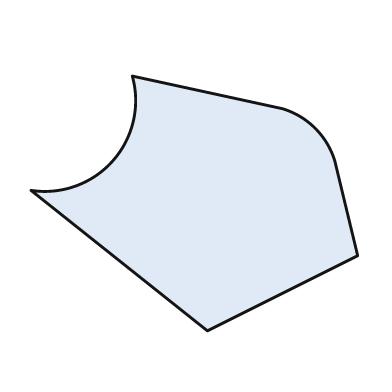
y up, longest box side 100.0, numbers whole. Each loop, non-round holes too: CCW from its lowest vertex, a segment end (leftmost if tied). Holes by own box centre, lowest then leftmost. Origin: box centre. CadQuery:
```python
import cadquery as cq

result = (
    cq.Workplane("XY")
    .moveTo(4.0, -39.0)
    .lineTo(50.0, -16.0)
    .lineTo(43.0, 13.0)
    .threePointArc((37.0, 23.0), (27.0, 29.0))
    .lineTo(-19.0, 39.0)
    .threePointArc((-25.0, 13.0), (-50.0, 4.0))
    .close()
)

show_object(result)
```